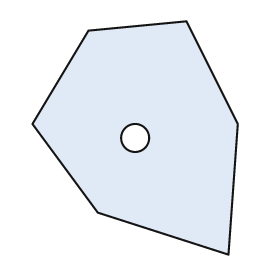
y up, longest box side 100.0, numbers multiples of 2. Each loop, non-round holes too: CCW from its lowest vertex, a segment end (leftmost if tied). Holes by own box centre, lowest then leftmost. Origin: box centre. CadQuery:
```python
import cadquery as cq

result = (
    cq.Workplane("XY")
    .moveTo(40.0, -50.0)
    .lineTo(44.0, 6.0)
    .lineTo(22.0, 50.0)
    .lineTo(-20.0, 46.0)
    .lineTo(-44.0, 6.0)
    .lineTo(-16.0, -32.0)
    .close()
    .moveTo(0.0, 0.0)
    .circle(6.0)
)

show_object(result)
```